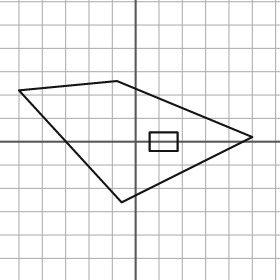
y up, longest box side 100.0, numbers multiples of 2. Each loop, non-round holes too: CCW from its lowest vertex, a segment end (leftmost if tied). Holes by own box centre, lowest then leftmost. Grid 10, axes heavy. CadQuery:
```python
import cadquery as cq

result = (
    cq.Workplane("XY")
    .moveTo(-6.0, -26.0)
    .lineTo(50.0, 2.0)
    .lineTo(-8.0, 26.0)
    .lineTo(-50.0, 22.0)
    .close()
    .moveTo(6.0, -4.0)
    .lineTo(18.0, -4.0)
    .lineTo(18.0, 4.0)
    .lineTo(6.0, 4.0)
    .close()
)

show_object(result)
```